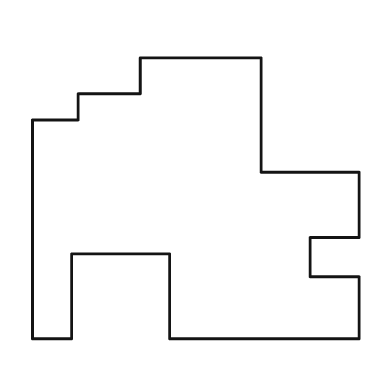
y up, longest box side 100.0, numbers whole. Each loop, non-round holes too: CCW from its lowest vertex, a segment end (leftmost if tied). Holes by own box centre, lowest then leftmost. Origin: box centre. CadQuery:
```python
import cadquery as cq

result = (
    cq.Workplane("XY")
    .moveTo(-50.0, -43.0)
    .lineTo(-38.0, -43.0)
    .lineTo(-38.0, -17.0)
    .lineTo(-8.0, -17.0)
    .lineTo(-8.0, -43.0)
    .lineTo(50.0, -43.0)
    .lineTo(50.0, -24.0)
    .lineTo(35.0, -24.0)
    .lineTo(35.0, -12.0)
    .lineTo(50.0, -12.0)
    .lineTo(50.0, 8.0)
    .lineTo(20.0, 8.0)
    .lineTo(20.0, 43.0)
    .lineTo(-17.0, 43.0)
    .lineTo(-17.0, 32.0)
    .lineTo(-36.0, 32.0)
    .lineTo(-36.0, 24.0)
    .lineTo(-50.0, 24.0)
    .close()
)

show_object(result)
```